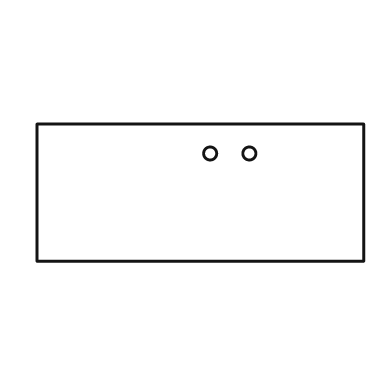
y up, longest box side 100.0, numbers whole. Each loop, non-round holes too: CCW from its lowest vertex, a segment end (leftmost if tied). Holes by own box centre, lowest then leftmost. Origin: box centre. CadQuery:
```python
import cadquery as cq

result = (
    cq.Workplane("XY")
    .moveTo(-50.0, -21.0)
    .lineTo(50.0, -21.0)
    .lineTo(50.0, 21.0)
    .lineTo(-50.0, 21.0)
    .close()
    .moveTo(3.0, 12.0)
    .circle(2.0)
    .moveTo(15.0, 12.0)
    .circle(2.0)
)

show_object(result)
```